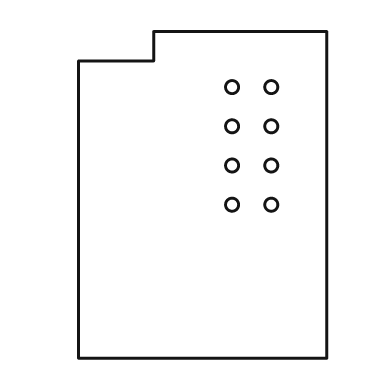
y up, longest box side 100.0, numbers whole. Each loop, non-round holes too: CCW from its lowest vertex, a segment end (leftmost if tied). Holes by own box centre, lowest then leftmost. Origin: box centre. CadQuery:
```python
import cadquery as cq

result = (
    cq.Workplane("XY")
    .moveTo(-38.0, -50.0)
    .lineTo(38.0, -50.0)
    .lineTo(38.0, 50.0)
    .lineTo(-15.0, 50.0)
    .lineTo(-15.0, 41.0)
    .lineTo(-38.0, 41.0)
    .close()
    .moveTo(9.0, -3.0)
    .circle(2.0)
    .moveTo(21.0, -3.0)
    .circle(2.0)
    .moveTo(9.0, 9.0)
    .circle(2.0)
    .moveTo(21.0, 9.0)
    .circle(2.0)
    .moveTo(9.0, 21.0)
    .circle(2.0)
    .moveTo(21.0, 21.0)
    .circle(2.0)
    .moveTo(9.0, 33.0)
    .circle(2.0)
    .moveTo(21.0, 33.0)
    .circle(2.0)
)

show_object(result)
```